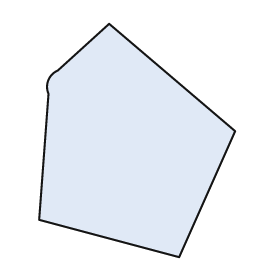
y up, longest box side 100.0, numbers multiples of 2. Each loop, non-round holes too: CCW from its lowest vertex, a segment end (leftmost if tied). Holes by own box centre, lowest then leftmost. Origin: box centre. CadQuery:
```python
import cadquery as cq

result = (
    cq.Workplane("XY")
    .moveTo(18.0, -50.0)
    .lineTo(42.0, 4.0)
    .lineTo(-12.0, 50.0)
    .lineTo(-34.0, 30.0)
    .threePointArc((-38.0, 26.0), (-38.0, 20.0))
    .lineTo(-42.0, -34.0)
    .close()
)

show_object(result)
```